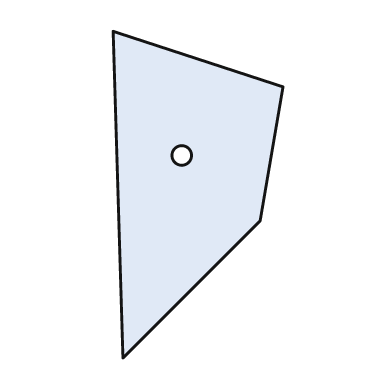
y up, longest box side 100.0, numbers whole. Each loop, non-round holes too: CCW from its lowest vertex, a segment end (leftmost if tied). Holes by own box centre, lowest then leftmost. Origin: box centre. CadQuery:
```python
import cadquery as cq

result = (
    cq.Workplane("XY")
    .moveTo(-23.0, -50.0)
    .lineTo(19.0, -8.0)
    .lineTo(26.0, 33.0)
    .lineTo(-26.0, 50.0)
    .close()
    .moveTo(-5.0, 12.0)
    .circle(3.0)
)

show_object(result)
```